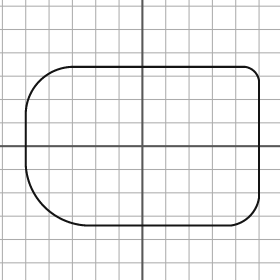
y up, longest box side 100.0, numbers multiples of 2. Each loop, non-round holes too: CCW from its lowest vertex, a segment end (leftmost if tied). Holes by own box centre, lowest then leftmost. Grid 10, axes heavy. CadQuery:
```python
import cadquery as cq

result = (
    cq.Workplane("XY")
    .moveTo(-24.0, -34.0)
    .lineTo(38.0, -34.0)
    .threePointArc((46.0, -30.0), (50.0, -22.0))
    .lineTo(50.0, 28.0)
    .threePointArc((48.0, 32.0), (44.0, 34.0))
    .lineTo(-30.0, 34.0)
    .threePointArc((-44.0, 28.0), (-50.0, 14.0))
    .lineTo(-50.0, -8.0)
    .threePointArc((-42.0, -26.0), (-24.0, -34.0))
    .close()
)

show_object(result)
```